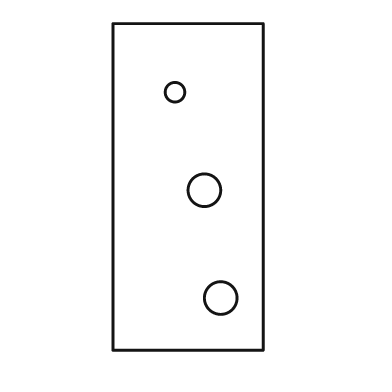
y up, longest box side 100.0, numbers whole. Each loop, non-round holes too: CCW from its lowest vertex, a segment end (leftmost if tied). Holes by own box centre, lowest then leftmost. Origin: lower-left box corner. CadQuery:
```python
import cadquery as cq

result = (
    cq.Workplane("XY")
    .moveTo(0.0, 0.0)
    .lineTo(46.0, 0.0)
    .lineTo(46.0, 100.0)
    .lineTo(0.0, 100.0)
    .close()
    .moveTo(33.0, 16.0)
    .circle(5.0)
    .moveTo(28.0, 49.0)
    .circle(5.0)
    .moveTo(19.0, 79.0)
    .circle(3.0)
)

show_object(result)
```